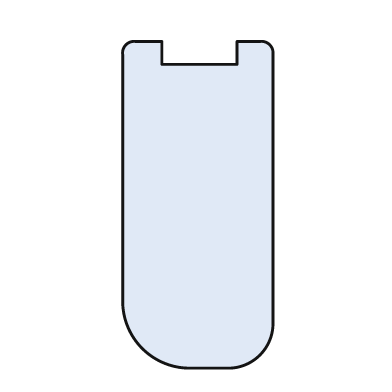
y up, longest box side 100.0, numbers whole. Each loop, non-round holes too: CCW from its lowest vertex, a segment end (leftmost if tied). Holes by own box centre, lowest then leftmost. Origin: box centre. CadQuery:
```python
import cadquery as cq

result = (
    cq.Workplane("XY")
    .moveTo(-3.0, -50.0)
    .lineTo(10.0, -50.0)
    .threePointArc((19.0, -46.0), (23.0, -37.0))
    .lineTo(23.0, 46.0)
    .threePointArc((22.0, 49.0), (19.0, 50.0))
    .lineTo(12.0, 50.0)
    .lineTo(12.0, 43.0)
    .lineTo(-11.0, 43.0)
    .lineTo(-11.0, 50.0)
    .lineTo(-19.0, 50.0)
    .threePointArc((-22.0, 49.0), (-23.0, 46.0))
    .lineTo(-23.0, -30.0)
    .threePointArc((-17.0, -44.0), (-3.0, -50.0))
    .close()
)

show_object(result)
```